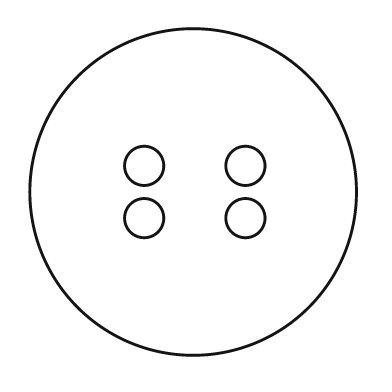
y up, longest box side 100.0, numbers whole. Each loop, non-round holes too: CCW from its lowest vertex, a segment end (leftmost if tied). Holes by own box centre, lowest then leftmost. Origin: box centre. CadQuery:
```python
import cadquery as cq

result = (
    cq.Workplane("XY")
    .moveTo(0.0, 0.0)
    .circle(50.0)
    .moveTo(-15.0, -8.0)
    .circle(6.0)
    .moveTo(16.0, -8.0)
    .circle(6.0)
    .moveTo(-15.0, 8.0)
    .circle(6.0)
    .moveTo(16.0, 8.0)
    .circle(6.0)
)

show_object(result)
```